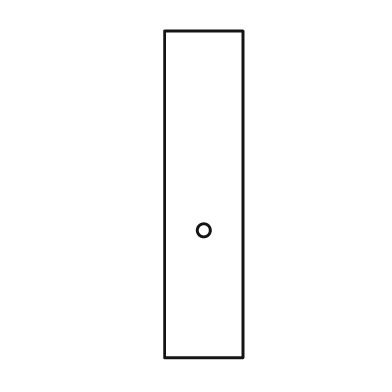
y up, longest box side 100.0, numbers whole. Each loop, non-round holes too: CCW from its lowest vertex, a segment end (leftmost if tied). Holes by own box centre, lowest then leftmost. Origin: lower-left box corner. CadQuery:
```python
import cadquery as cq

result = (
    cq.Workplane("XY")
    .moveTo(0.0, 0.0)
    .lineTo(24.0, 0.0)
    .lineTo(24.0, 100.0)
    .lineTo(0.0, 100.0)
    .close()
    .moveTo(12.0, 39.0)
    .circle(2.0)
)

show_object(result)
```